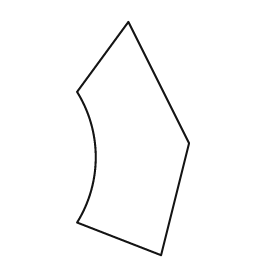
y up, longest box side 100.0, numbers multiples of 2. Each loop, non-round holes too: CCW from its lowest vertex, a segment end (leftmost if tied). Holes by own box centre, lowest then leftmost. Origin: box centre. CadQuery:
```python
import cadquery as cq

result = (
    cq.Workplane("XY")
    .moveTo(12.0, -50.0)
    .lineTo(24.0, -2.0)
    .lineTo(-2.0, 50.0)
    .lineTo(-24.0, 20.0)
    .threePointArc((-16.0, -8.0), (-24.0, -36.0))
    .close()
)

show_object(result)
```